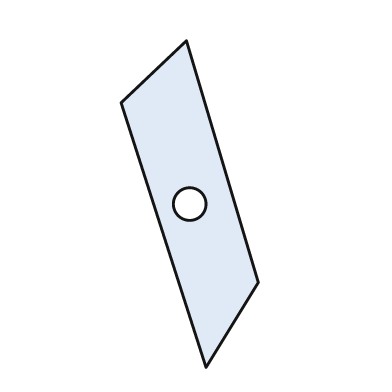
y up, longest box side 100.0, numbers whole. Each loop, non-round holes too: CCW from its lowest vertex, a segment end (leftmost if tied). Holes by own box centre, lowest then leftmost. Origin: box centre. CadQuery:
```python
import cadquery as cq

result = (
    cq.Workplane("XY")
    .moveTo(5.0, -50.0)
    .lineTo(21.0, -24.0)
    .lineTo(-1.0, 50.0)
    .lineTo(-21.0, 31.0)
    .close()
    .moveTo(0.0, 0.0)
    .circle(5.0)
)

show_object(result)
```